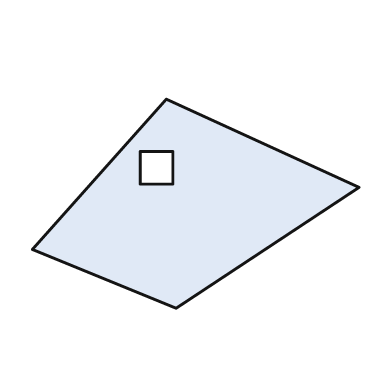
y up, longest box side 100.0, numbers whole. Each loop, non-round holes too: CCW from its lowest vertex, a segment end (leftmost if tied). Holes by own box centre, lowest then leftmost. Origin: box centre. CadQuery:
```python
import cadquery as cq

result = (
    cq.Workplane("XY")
    .moveTo(-6.0, -32.0)
    .lineTo(50.0, 5.0)
    .lineTo(-9.0, 32.0)
    .lineTo(-50.0, -14.0)
    .close()
    .moveTo(-17.0, 6.0)
    .lineTo(-7.0, 6.0)
    .lineTo(-7.0, 16.0)
    .lineTo(-17.0, 16.0)
    .close()
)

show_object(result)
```